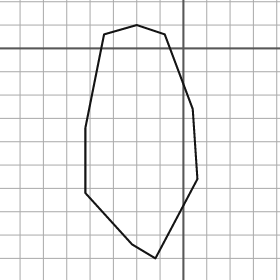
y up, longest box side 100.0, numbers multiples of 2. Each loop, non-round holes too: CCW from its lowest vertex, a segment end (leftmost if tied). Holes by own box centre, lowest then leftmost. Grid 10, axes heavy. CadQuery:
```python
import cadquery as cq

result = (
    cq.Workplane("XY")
    .moveTo(-12.0, -90.0)
    .lineTo(6.0, -56.0)
    .lineTo(4.0, -26.0)
    .lineTo(-8.0, 6.0)
    .lineTo(-20.0, 10.0)
    .lineTo(-34.0, 6.0)
    .lineTo(-42.0, -34.0)
    .lineTo(-42.0, -62.0)
    .lineTo(-22.0, -84.0)
    .close()
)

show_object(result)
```